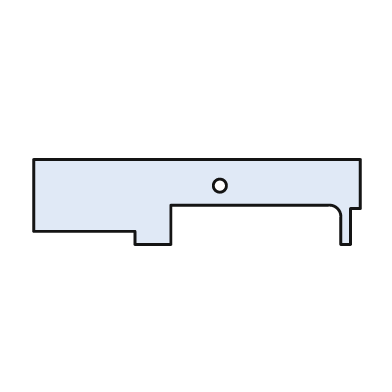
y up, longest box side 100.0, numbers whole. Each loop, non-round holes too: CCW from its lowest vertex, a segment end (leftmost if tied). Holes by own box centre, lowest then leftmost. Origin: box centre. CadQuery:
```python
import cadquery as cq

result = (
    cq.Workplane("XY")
    .moveTo(-19.0, -13.0)
    .lineTo(-8.0, -13.0)
    .lineTo(-8.0, -1.0)
    .lineTo(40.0, -1.0)
    .threePointArc((43.0, -2.0), (44.0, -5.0))
    .lineTo(44.0, -13.0)
    .lineTo(47.0, -13.0)
    .lineTo(47.0, -2.0)
    .lineTo(50.0, -2.0)
    .lineTo(50.0, 13.0)
    .lineTo(-50.0, 13.0)
    .lineTo(-50.0, -9.0)
    .lineTo(-19.0, -9.0)
    .close()
    .moveTo(7.0, 5.0)
    .circle(2.0)
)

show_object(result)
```